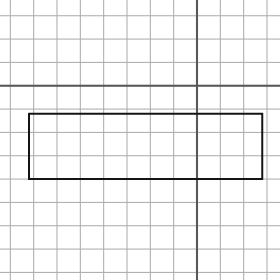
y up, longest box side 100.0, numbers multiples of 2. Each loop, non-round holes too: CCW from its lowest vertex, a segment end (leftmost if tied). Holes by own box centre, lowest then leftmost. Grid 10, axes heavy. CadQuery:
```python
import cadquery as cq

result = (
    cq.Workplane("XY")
    .moveTo(-72.0, -40.0)
    .lineTo(28.0, -40.0)
    .lineTo(28.0, -12.0)
    .lineTo(-72.0, -12.0)
    .close()
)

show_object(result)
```